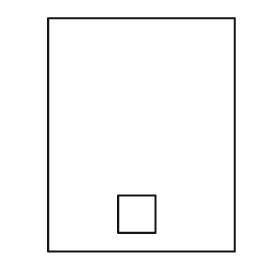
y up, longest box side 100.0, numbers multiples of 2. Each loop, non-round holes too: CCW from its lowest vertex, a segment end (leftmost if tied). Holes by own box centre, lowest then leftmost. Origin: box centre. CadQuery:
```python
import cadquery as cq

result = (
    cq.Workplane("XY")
    .moveTo(-40.0, -50.0)
    .lineTo(40.0, -50.0)
    .lineTo(40.0, 50.0)
    .lineTo(-40.0, 50.0)
    .close()
    .moveTo(-10.0, -42.0)
    .lineTo(6.0, -42.0)
    .lineTo(6.0, -26.0)
    .lineTo(-10.0, -26.0)
    .close()
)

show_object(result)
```